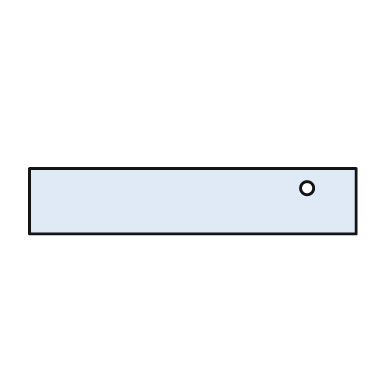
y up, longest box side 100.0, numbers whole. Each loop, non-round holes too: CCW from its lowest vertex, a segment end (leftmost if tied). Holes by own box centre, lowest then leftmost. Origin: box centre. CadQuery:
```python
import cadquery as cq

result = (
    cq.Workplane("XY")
    .moveTo(-50.0, -10.0)
    .lineTo(50.0, -10.0)
    .lineTo(50.0, 10.0)
    .lineTo(-50.0, 10.0)
    .close()
    .moveTo(35.0, 4.0)
    .circle(2.0)
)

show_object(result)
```